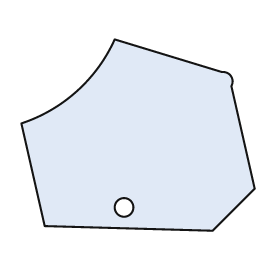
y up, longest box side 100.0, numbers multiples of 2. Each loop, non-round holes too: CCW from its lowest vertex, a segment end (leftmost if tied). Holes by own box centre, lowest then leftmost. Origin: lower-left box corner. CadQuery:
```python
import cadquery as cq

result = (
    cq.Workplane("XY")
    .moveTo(82.0, 0.0)
    .lineTo(100.0, 18.0)
    .lineTo(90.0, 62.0)
    .threePointArc((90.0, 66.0), (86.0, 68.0))
    .lineTo(40.0, 82.0)
    .threePointArc((24.0, 60.0), (0.0, 46.0))
    .lineTo(10.0, 2.0)
    .close()
    .moveTo(44.0, 10.0)
    .circle(4.0)
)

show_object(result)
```